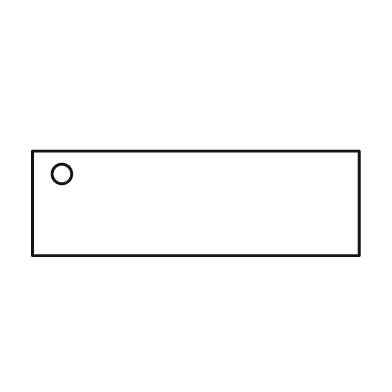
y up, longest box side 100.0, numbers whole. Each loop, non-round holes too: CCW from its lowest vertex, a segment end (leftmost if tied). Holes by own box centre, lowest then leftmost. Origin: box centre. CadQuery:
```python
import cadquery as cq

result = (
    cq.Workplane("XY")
    .moveTo(-50.0, -16.0)
    .lineTo(50.0, -16.0)
    .lineTo(50.0, 16.0)
    .lineTo(-50.0, 16.0)
    .close()
    .moveTo(-41.0, 9.0)
    .circle(3.0)
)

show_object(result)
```